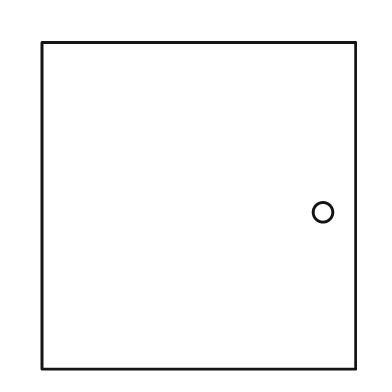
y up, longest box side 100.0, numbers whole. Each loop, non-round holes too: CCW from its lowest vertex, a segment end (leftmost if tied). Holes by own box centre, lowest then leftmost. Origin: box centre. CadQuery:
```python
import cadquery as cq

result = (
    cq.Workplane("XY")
    .moveTo(-48.0, -50.0)
    .lineTo(48.0, -50.0)
    .lineTo(48.0, 50.0)
    .lineTo(-48.0, 50.0)
    .close()
    .moveTo(38.0, -2.0)
    .circle(3.0)
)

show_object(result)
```